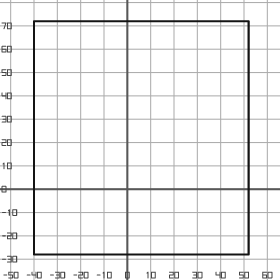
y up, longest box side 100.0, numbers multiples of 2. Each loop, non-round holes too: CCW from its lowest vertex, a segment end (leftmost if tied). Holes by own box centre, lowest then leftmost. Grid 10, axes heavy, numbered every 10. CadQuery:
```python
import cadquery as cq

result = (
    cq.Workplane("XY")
    .moveTo(-40.0, -28.0)
    .lineTo(52.0, -28.0)
    .lineTo(52.0, 72.0)
    .lineTo(-40.0, 72.0)
    .close()
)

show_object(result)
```